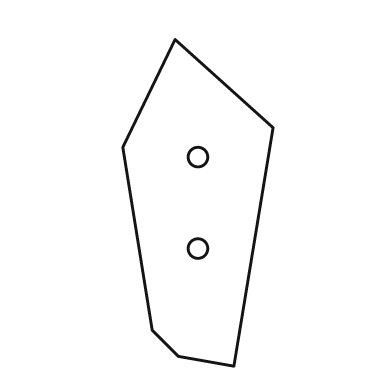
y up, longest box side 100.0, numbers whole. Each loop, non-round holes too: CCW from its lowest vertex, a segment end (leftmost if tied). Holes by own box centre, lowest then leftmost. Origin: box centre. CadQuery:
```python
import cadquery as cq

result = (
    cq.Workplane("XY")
    .moveTo(11.0, -50.0)
    .lineTo(23.0, 23.0)
    .lineTo(-7.0, 50.0)
    .lineTo(-23.0, 17.0)
    .lineTo(-14.0, -39.0)
    .lineTo(-6.0, -47.0)
    .close()
    .moveTo(0.0, -14.0)
    .circle(3.0)
    .moveTo(0.0, 14.0)
    .circle(3.0)
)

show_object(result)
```